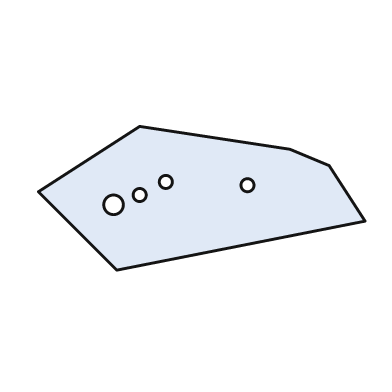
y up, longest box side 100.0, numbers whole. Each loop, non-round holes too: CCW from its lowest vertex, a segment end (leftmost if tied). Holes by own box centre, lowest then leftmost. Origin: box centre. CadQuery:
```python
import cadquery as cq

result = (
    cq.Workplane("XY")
    .moveTo(-26.0, -22.0)
    .lineTo(50.0, -7.0)
    .lineTo(39.0, 10.0)
    .lineTo(27.0, 15.0)
    .lineTo(-19.0, 22.0)
    .lineTo(-50.0, 2.0)
    .close()
    .moveTo(-27.0, -2.0)
    .circle(3.0)
    .moveTo(-19.0, 1.0)
    .circle(2.0)
    .moveTo(14.0, 4.0)
    .circle(2.0)
    .moveTo(-11.0, 5.0)
    .circle(2.0)
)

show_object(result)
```